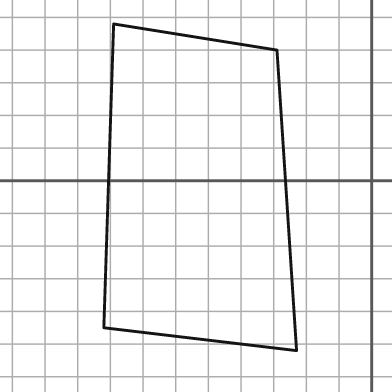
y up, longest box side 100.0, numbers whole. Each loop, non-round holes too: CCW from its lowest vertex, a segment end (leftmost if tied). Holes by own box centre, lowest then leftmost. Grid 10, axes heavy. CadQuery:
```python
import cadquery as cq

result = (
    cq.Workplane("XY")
    .moveTo(-23.0, -52.0)
    .lineTo(-29.0, 40.0)
    .lineTo(-79.0, 48.0)
    .lineTo(-82.0, -45.0)
    .close()
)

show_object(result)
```